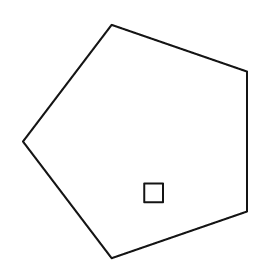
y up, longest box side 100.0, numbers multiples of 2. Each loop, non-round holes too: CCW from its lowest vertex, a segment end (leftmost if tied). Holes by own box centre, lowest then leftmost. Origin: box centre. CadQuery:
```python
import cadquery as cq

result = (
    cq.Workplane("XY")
    .moveTo(-10.0, -50.0)
    .lineTo(48.0, -30.0)
    .lineTo(48.0, 30.0)
    .lineTo(-10.0, 50.0)
    .lineTo(-48.0, 0.0)
    .close()
    .moveTo(4.0, -26.0)
    .lineTo(12.0, -26.0)
    .lineTo(12.0, -18.0)
    .lineTo(4.0, -18.0)
    .close()
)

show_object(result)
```